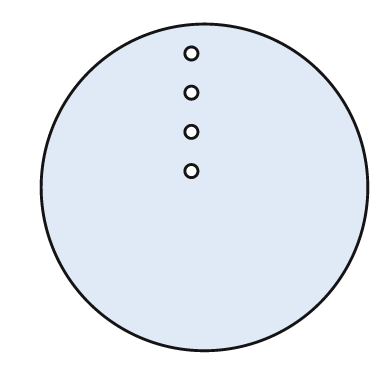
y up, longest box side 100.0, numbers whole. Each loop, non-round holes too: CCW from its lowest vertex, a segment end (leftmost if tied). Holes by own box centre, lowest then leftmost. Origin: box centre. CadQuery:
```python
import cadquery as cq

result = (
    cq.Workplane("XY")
    .moveTo(0.0, 0.0)
    .circle(50.0)
    .moveTo(-4.0, 5.0)
    .circle(2.0)
    .moveTo(-4.0, 17.0)
    .circle(2.0)
    .moveTo(-4.0, 29.0)
    .circle(2.0)
    .moveTo(-4.0, 41.0)
    .circle(2.0)
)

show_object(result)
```